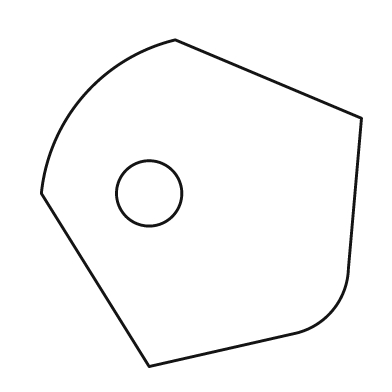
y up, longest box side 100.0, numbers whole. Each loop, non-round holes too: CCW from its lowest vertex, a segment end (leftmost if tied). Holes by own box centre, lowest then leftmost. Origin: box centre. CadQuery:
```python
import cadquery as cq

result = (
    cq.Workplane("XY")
    .moveTo(-16.0, -50.0)
    .lineTo(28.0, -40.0)
    .threePointArc((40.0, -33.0), (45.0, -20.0))
    .lineTo(49.0, 26.0)
    .lineTo(-8.0, 50.0)
    .threePointArc((-36.0, 33.0), (-49.0, 3.0))
    .close()
    .moveTo(-16.0, 3.0)
    .circle(10.0)
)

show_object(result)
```